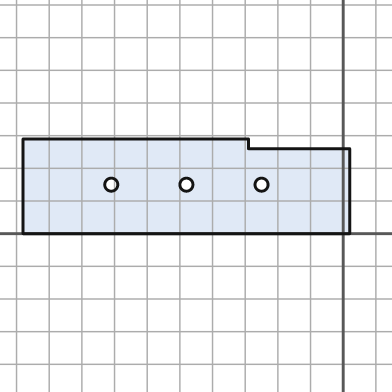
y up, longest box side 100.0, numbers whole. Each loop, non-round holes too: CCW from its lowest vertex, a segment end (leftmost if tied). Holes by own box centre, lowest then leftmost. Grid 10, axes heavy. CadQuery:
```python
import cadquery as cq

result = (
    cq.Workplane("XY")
    .moveTo(-98.0, 0.0)
    .lineTo(2.0, 0.0)
    .lineTo(2.0, 26.0)
    .lineTo(-29.0, 26.0)
    .lineTo(-29.0, 29.0)
    .lineTo(-98.0, 29.0)
    .close()
    .moveTo(-71.0, 15.0)
    .circle(2.0)
    .moveTo(-48.0, 15.0)
    .circle(2.0)
    .moveTo(-25.0, 15.0)
    .circle(2.0)
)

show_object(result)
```